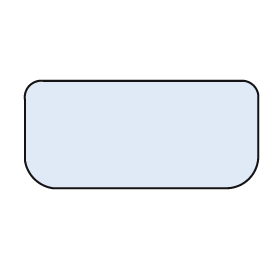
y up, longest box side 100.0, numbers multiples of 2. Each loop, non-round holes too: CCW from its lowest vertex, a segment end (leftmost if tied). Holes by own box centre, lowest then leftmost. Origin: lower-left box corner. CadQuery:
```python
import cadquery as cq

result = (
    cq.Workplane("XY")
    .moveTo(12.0, 0.0)
    .lineTo(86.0, 0.0)
    .threePointArc((96.0, 4.0), (100.0, 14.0))
    .lineTo(100.0, 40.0)
    .threePointArc((98.0, 44.0), (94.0, 46.0))
    .lineTo(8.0, 46.0)
    .threePointArc((2.0, 44.0), (0.0, 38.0))
    .lineTo(0.0, 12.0)
    .threePointArc((4.0, 4.0), (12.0, 0.0))
    .close()
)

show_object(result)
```